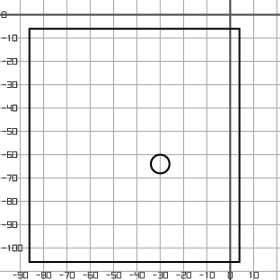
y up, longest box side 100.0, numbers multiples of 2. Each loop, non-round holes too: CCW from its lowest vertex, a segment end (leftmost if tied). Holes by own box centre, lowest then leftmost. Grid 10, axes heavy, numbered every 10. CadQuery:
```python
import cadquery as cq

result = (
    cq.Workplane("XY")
    .moveTo(-86.0, -106.0)
    .lineTo(4.0, -106.0)
    .lineTo(4.0, -6.0)
    .lineTo(-86.0, -6.0)
    .close()
    .moveTo(-30.0, -64.0)
    .circle(4.0)
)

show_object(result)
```